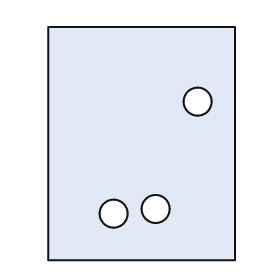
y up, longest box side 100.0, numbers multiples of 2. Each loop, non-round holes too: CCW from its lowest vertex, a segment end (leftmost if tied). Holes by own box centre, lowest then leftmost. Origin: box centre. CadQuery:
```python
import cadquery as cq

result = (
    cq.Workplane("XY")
    .moveTo(-40.0, -50.0)
    .lineTo(40.0, -50.0)
    .lineTo(40.0, 50.0)
    .lineTo(-40.0, 50.0)
    .close()
    .moveTo(-12.0, -30.0)
    .circle(6.0)
    .moveTo(6.0, -28.0)
    .circle(6.0)
    .moveTo(24.0, 18.0)
    .circle(6.0)
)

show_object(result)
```